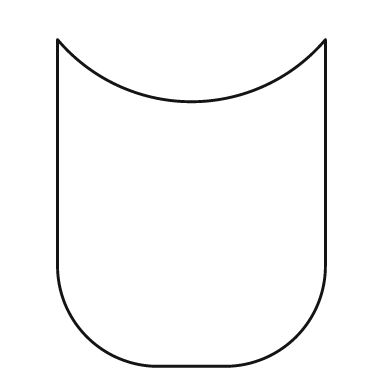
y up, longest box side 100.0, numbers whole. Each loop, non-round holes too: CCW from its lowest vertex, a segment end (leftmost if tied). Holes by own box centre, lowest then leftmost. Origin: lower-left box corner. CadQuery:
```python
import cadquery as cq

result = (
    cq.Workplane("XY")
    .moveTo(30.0, 0.0)
    .lineTo(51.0, 0.0)
    .threePointArc((73.0, 9.0), (82.0, 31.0))
    .lineTo(82.0, 100.0)
    .threePointArc((41.0, 81.0), (0.0, 100.0))
    .lineTo(0.0, 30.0)
    .threePointArc((9.0, 9.0), (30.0, 0.0))
    .close()
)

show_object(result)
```